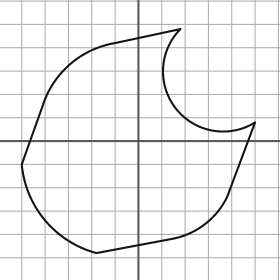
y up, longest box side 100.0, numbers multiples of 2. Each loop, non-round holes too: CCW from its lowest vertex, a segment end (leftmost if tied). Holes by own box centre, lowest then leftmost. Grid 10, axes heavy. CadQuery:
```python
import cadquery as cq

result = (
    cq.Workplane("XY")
    .moveTo(-18.0, -48.0)
    .lineTo(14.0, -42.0)
    .threePointArc((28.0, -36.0), (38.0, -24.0))
    .lineTo(50.0, 8.0)
    .threePointArc((16.0, 14.0), (18.0, 48.0))
    .lineTo(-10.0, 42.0)
    .threePointArc((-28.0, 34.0), (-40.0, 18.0))
    .lineTo(-50.0, -10.0)
    .threePointArc((-40.0, -34.0), (-18.0, -48.0))
    .close()
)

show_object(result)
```